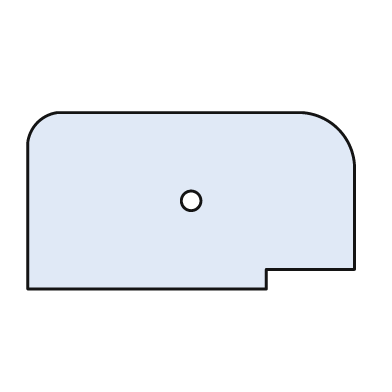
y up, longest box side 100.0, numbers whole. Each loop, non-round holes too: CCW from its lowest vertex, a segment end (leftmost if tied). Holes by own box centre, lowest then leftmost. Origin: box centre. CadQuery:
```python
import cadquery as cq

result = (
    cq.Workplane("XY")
    .moveTo(-50.0, -27.0)
    .lineTo(23.0, -27.0)
    .lineTo(23.0, -21.0)
    .lineTo(50.0, -21.0)
    .lineTo(50.0, 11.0)
    .threePointArc((45.0, 22.0), (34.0, 27.0))
    .lineTo(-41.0, 27.0)
    .threePointArc((-47.0, 24.0), (-50.0, 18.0))
    .close()
    .moveTo(0.0, 0.0)
    .circle(3.0)
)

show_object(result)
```